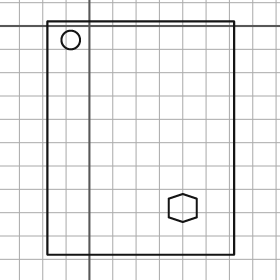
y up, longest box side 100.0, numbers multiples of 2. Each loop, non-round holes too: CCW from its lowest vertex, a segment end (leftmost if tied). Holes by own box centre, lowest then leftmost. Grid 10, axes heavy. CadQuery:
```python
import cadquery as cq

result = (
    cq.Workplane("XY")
    .moveTo(-18.0, -98.0)
    .lineTo(62.0, -98.0)
    .lineTo(62.0, 2.0)
    .lineTo(-18.0, 2.0)
    .close()
    .moveTo(40.0, -84.0)
    .lineTo(46.0, -82.0)
    .lineTo(46.0, -74.0)
    .lineTo(40.0, -72.0)
    .lineTo(34.0, -74.0)
    .lineTo(34.0, -82.0)
    .close()
    .moveTo(-8.0, -6.0)
    .circle(4.0)
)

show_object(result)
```